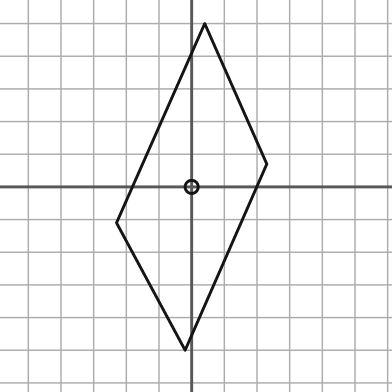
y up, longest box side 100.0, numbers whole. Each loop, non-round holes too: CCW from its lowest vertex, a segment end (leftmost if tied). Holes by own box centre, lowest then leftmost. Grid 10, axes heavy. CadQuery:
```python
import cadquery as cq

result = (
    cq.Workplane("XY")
    .moveTo(-2.0, -50.0)
    .lineTo(23.0, 7.0)
    .lineTo(4.0, 50.0)
    .lineTo(-23.0, -11.0)
    .close()
    .moveTo(0.0, 0.0)
    .circle(2.0)
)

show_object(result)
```